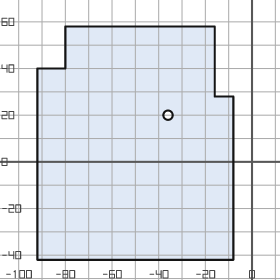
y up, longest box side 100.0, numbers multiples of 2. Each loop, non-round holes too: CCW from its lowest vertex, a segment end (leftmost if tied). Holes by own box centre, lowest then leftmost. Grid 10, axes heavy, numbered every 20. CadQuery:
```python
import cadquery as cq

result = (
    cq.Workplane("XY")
    .moveTo(-92.0, -42.0)
    .lineTo(-8.0, -42.0)
    .lineTo(-8.0, 28.0)
    .lineTo(-16.0, 28.0)
    .lineTo(-16.0, 58.0)
    .lineTo(-80.0, 58.0)
    .lineTo(-80.0, 40.0)
    .lineTo(-92.0, 40.0)
    .close()
    .moveTo(-36.0, 20.0)
    .circle(2.0)
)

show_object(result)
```